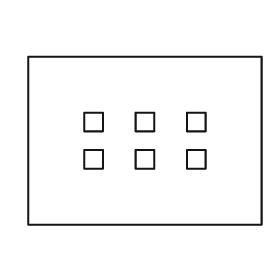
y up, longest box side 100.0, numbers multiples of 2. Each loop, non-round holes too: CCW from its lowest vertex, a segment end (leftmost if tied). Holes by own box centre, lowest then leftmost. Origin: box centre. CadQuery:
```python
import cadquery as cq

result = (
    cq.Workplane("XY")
    .moveTo(-50.0, -36.0)
    .lineTo(50.0, -36.0)
    .lineTo(50.0, 36.0)
    .lineTo(-50.0, 36.0)
    .close()
    .moveTo(-26.0, -12.0)
    .lineTo(-18.0, -12.0)
    .lineTo(-18.0, -4.0)
    .lineTo(-26.0, -4.0)
    .close()
    .moveTo(-4.0, -12.0)
    .lineTo(4.0, -12.0)
    .lineTo(4.0, -4.0)
    .lineTo(-4.0, -4.0)
    .close()
    .moveTo(18.0, -12.0)
    .lineTo(26.0, -12.0)
    .lineTo(26.0, -4.0)
    .lineTo(18.0, -4.0)
    .close()
    .moveTo(-26.0, 4.0)
    .lineTo(-18.0, 4.0)
    .lineTo(-18.0, 12.0)
    .lineTo(-26.0, 12.0)
    .close()
    .moveTo(-4.0, 4.0)
    .lineTo(4.0, 4.0)
    .lineTo(4.0, 12.0)
    .lineTo(-4.0, 12.0)
    .close()
    .moveTo(18.0, 4.0)
    .lineTo(26.0, 4.0)
    .lineTo(26.0, 12.0)
    .lineTo(18.0, 12.0)
    .close()
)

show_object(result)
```